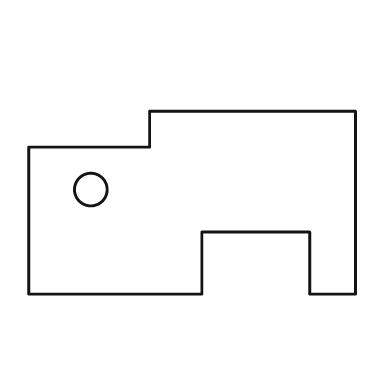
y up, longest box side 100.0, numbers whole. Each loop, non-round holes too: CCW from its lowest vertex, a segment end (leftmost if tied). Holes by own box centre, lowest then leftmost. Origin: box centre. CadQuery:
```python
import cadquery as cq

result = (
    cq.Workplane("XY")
    .moveTo(-50.0, -28.0)
    .lineTo(3.0, -28.0)
    .lineTo(3.0, -9.0)
    .lineTo(36.0, -9.0)
    .lineTo(36.0, -28.0)
    .lineTo(50.0, -28.0)
    .lineTo(50.0, 28.0)
    .lineTo(-13.0, 28.0)
    .lineTo(-13.0, 17.0)
    .lineTo(-50.0, 17.0)
    .close()
    .moveTo(-31.0, 4.0)
    .circle(5.0)
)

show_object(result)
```